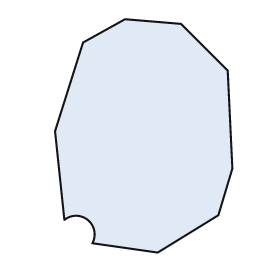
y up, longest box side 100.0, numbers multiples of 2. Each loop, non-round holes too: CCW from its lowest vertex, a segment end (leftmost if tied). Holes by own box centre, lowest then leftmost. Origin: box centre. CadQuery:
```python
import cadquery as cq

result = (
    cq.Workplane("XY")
    .moveTo(6.0, -50.0)
    .lineTo(32.0, -34.0)
    .lineTo(38.0, -14.0)
    .lineTo(36.0, 28.0)
    .lineTo(16.0, 48.0)
    .lineTo(-8.0, 50.0)
    .lineTo(-26.0, 40.0)
    .lineTo(-38.0, 2.0)
    .lineTo(-34.0, -36.0)
    .threePointArc((-24.0, -36.0), (-22.0, -46.0))
    .close()
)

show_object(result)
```